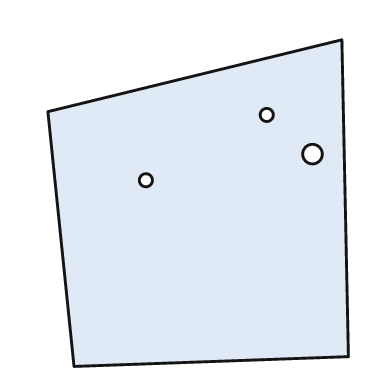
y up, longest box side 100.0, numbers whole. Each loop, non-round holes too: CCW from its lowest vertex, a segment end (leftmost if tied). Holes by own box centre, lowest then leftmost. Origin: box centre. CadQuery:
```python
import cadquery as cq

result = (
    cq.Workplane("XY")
    .moveTo(-38.0, -50.0)
    .lineTo(46.0, -47.0)
    .lineTo(44.0, 50.0)
    .lineTo(-46.0, 28.0)
    .close()
    .moveTo(-16.0, 7.0)
    .circle(2.0)
    .moveTo(35.0, 15.0)
    .circle(3.0)
    .moveTo(21.0, 27.0)
    .circle(2.0)
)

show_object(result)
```